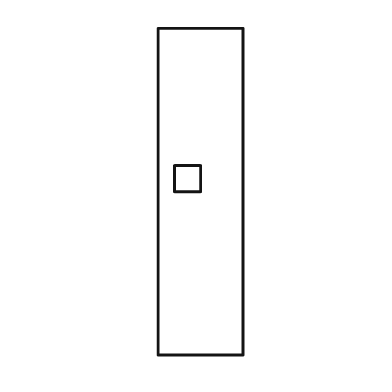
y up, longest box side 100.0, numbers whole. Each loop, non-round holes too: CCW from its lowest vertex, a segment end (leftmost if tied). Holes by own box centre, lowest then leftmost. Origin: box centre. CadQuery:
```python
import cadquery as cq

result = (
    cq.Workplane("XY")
    .moveTo(-13.0, -50.0)
    .lineTo(13.0, -50.0)
    .lineTo(13.0, 50.0)
    .lineTo(-13.0, 50.0)
    .close()
    .moveTo(-8.0, 0.0)
    .lineTo(0.0, 0.0)
    .lineTo(0.0, 8.0)
    .lineTo(-8.0, 8.0)
    .close()
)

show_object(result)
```